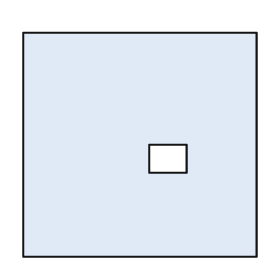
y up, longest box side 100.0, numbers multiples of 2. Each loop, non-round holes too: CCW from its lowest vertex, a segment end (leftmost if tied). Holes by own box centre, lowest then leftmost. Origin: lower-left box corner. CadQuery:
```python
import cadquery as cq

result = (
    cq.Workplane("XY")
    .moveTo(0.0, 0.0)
    .lineTo(100.0, 0.0)
    .lineTo(100.0, 96.0)
    .lineTo(0.0, 96.0)
    .close()
    .moveTo(54.0, 36.0)
    .lineTo(70.0, 36.0)
    .lineTo(70.0, 48.0)
    .lineTo(54.0, 48.0)
    .close()
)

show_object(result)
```